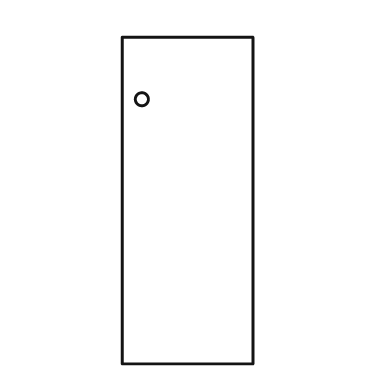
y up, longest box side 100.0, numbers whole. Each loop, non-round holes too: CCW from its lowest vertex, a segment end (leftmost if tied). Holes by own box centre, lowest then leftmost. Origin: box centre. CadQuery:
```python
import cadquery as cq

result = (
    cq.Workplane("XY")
    .moveTo(-20.0, -50.0)
    .lineTo(20.0, -50.0)
    .lineTo(20.0, 50.0)
    .lineTo(-20.0, 50.0)
    .close()
    .moveTo(-14.0, 31.0)
    .circle(2.0)
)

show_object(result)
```